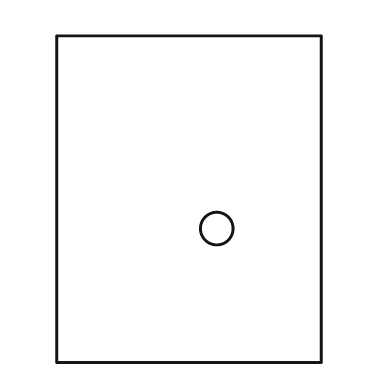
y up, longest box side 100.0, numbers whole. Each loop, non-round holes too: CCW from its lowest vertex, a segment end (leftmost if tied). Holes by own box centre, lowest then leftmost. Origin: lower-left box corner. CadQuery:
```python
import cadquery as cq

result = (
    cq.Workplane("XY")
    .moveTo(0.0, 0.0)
    .lineTo(81.0, 0.0)
    .lineTo(81.0, 100.0)
    .lineTo(0.0, 100.0)
    .close()
    .moveTo(49.0, 41.0)
    .circle(5.0)
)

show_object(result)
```